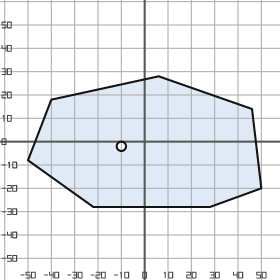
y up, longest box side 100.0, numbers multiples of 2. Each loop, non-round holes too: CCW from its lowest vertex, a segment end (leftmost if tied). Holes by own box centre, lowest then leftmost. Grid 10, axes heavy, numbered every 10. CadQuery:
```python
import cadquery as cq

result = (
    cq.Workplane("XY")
    .moveTo(-22.0, -28.0)
    .lineTo(28.0, -28.0)
    .lineTo(50.0, -20.0)
    .lineTo(46.0, 14.0)
    .lineTo(6.0, 28.0)
    .lineTo(-40.0, 18.0)
    .lineTo(-50.0, -8.0)
    .close()
    .moveTo(-10.0, -2.0)
    .circle(2.0)
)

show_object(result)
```